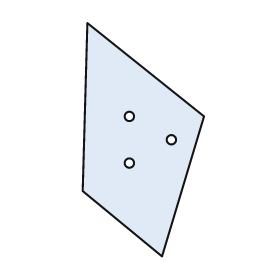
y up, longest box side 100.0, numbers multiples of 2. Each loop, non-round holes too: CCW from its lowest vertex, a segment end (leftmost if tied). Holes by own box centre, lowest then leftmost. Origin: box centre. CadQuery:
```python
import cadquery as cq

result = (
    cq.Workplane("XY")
    .moveTo(8.0, -50.0)
    .lineTo(26.0, 10.0)
    .lineTo(-24.0, 50.0)
    .lineTo(-26.0, -22.0)
    .close()
    .moveTo(-6.0, -10.0)
    .circle(2.0)
    .moveTo(12.0, 0.0)
    .circle(2.0)
    .moveTo(-6.0, 10.0)
    .circle(2.0)
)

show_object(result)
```